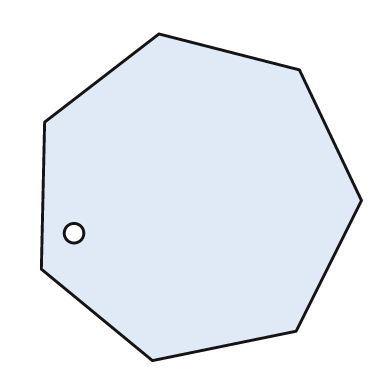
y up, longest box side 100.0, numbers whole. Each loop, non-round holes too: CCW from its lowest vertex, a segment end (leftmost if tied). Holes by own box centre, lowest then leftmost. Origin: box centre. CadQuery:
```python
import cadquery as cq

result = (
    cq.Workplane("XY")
    .moveTo(-15.0, -50.0)
    .lineTo(29.0, -41.0)
    .lineTo(49.0, -1.0)
    .lineTo(30.0, 39.0)
    .lineTo(-13.0, 50.0)
    .lineTo(-48.0, 23.0)
    .lineTo(-49.0, -22.0)
    .close()
    .moveTo(-39.0, -11.0)
    .circle(3.0)
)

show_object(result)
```